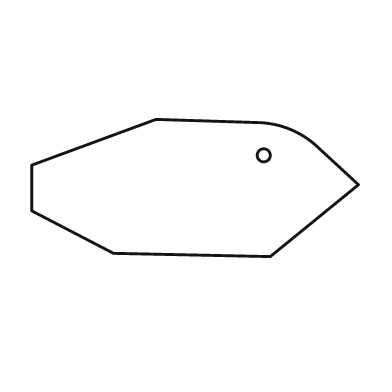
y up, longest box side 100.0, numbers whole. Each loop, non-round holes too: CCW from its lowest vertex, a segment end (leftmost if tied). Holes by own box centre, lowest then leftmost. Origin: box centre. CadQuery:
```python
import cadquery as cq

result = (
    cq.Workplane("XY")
    .moveTo(23.0, -21.0)
    .lineTo(50.0, 1.0)
    .lineTo(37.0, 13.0)
    .threePointArc((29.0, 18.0), (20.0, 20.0))
    .lineTo(-12.0, 21.0)
    .lineTo(-50.0, 7.0)
    .lineTo(-50.0, -7.0)
    .lineTo(-25.0, -20.0)
    .close()
    .moveTo(21.0, 10.0)
    .circle(2.0)
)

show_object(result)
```